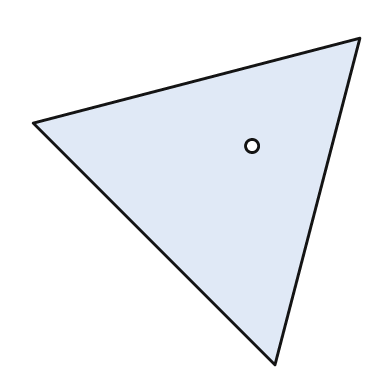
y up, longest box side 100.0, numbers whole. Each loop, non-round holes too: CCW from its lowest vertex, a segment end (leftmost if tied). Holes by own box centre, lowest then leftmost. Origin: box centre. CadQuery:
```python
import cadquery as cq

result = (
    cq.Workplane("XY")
    .moveTo(24.0, -50.0)
    .lineTo(50.0, 50.0)
    .lineTo(-50.0, 24.0)
    .close()
    .moveTo(17.0, 17.0)
    .circle(2.0)
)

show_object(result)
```